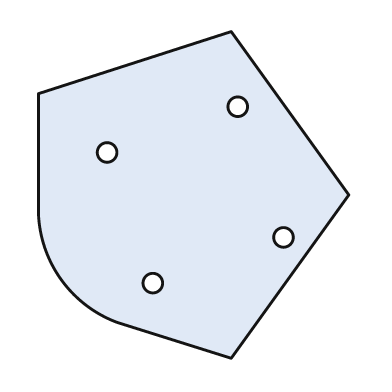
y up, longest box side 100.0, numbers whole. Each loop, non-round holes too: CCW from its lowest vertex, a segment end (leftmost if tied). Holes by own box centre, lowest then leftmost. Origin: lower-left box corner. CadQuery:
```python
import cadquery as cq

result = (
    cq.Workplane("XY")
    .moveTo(59.0, 0.0)
    .lineTo(95.0, 50.0)
    .lineTo(59.0, 100.0)
    .lineTo(0.0, 81.0)
    .lineTo(0.0, 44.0)
    .threePointArc((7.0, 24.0), (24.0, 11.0))
    .close()
    .moveTo(35.0, 23.0)
    .circle(3.0)
    .moveTo(75.0, 37.0)
    .circle(3.0)
    .moveTo(21.0, 63.0)
    .circle(3.0)
    .moveTo(61.0, 77.0)
    .circle(3.0)
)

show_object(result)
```